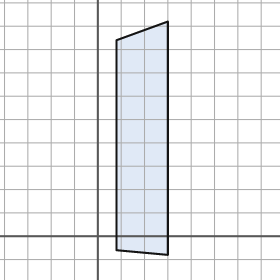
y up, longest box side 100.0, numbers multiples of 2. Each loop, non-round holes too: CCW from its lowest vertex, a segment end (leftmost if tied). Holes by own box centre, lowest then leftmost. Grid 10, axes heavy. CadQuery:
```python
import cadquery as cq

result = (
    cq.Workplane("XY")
    .moveTo(30.0, -8.0)
    .lineTo(30.0, 92.0)
    .lineTo(8.0, 84.0)
    .lineTo(8.0, -6.0)
    .close()
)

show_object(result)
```